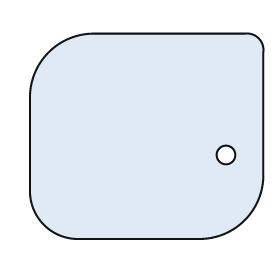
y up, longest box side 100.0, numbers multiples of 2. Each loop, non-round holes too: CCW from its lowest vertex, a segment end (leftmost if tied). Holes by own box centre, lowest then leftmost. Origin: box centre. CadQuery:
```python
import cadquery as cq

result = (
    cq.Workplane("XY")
    .moveTo(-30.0, -44.0)
    .lineTo(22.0, -44.0)
    .threePointArc((42.0, -36.0), (50.0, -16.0))
    .lineTo(50.0, 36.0)
    .threePointArc((48.0, 42.0), (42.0, 44.0))
    .lineTo(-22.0, 44.0)
    .threePointArc((-42.0, 36.0), (-50.0, 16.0))
    .lineTo(-50.0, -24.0)
    .threePointArc((-44.0, -38.0), (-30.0, -44.0))
    .close()
    .moveTo(34.0, -8.0)
    .circle(4.0)
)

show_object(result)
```